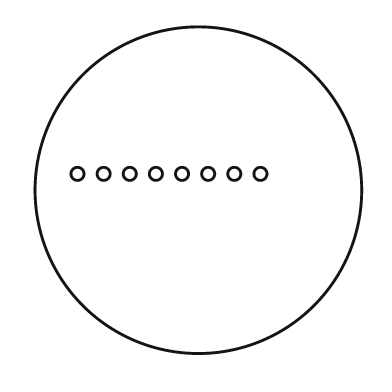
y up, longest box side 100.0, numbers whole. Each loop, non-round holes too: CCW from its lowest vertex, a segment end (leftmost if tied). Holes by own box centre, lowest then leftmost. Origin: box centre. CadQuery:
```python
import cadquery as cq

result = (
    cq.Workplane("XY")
    .moveTo(0.0, 0.0)
    .circle(50.0)
    .moveTo(-37.0, 5.0)
    .circle(2.0)
    .moveTo(-29.0, 5.0)
    .circle(2.0)
    .moveTo(-21.0, 5.0)
    .circle(2.0)
    .moveTo(-13.0, 5.0)
    .circle(2.0)
    .moveTo(-5.0, 5.0)
    .circle(2.0)
    .moveTo(3.0, 5.0)
    .circle(2.0)
    .moveTo(11.0, 5.0)
    .circle(2.0)
    .moveTo(19.0, 5.0)
    .circle(2.0)
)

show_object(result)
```